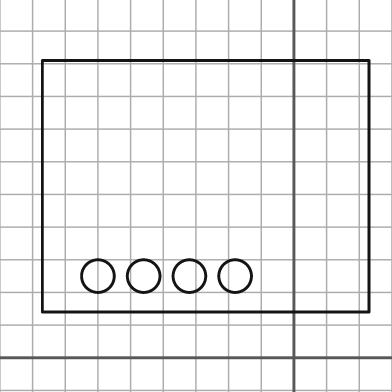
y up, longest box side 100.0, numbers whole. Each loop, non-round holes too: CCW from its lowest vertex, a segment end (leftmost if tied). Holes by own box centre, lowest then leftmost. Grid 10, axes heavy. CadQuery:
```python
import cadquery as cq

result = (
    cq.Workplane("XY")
    .moveTo(-77.0, 14.0)
    .lineTo(23.0, 14.0)
    .lineTo(23.0, 91.0)
    .lineTo(-77.0, 91.0)
    .close()
    .moveTo(-60.0, 25.0)
    .circle(5.0)
    .moveTo(-46.0, 25.0)
    .circle(5.0)
    .moveTo(-32.0, 25.0)
    .circle(5.0)
    .moveTo(-18.0, 25.0)
    .circle(5.0)
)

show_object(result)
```